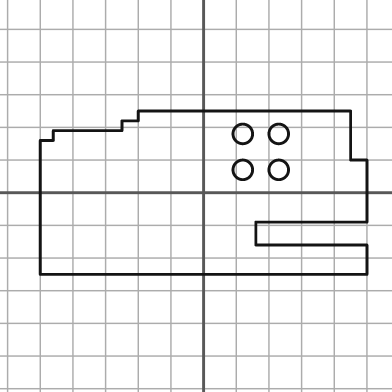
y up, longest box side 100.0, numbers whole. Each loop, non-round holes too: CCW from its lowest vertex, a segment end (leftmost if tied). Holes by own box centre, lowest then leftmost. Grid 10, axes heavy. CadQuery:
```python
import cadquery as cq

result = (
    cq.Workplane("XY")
    .moveTo(-50.0, -25.0)
    .lineTo(50.0, -25.0)
    .lineTo(50.0, -16.0)
    .lineTo(16.0, -16.0)
    .lineTo(16.0, -9.0)
    .lineTo(50.0, -9.0)
    .lineTo(50.0, 10.0)
    .lineTo(45.0, 10.0)
    .lineTo(45.0, 25.0)
    .lineTo(-20.0, 25.0)
    .lineTo(-20.0, 22.0)
    .lineTo(-25.0, 22.0)
    .lineTo(-25.0, 19.0)
    .lineTo(-46.0, 19.0)
    .lineTo(-46.0, 16.0)
    .lineTo(-50.0, 16.0)
    .close()
    .moveTo(12.0, 7.0)
    .circle(3.0)
    .moveTo(23.0, 7.0)
    .circle(3.0)
    .moveTo(12.0, 18.0)
    .circle(3.0)
    .moveTo(23.0, 18.0)
    .circle(3.0)
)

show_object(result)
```